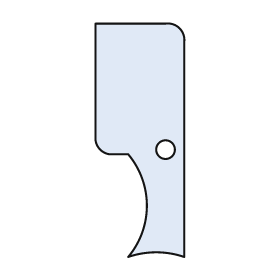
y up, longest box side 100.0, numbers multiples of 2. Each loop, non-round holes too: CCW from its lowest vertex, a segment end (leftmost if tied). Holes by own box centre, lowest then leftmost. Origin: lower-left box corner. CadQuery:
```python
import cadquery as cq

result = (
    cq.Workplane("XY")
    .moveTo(14.0, 0.0)
    .threePointArc((26.0, 2.0), (38.0, 0.0))
    .lineTo(38.0, 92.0)
    .threePointArc((36.0, 98.0), (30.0, 100.0))
    .lineTo(0.0, 100.0)
    .lineTo(0.0, 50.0)
    .threePointArc((2.0, 46.0), (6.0, 44.0))
    .lineTo(14.0, 44.0)
    .threePointArc((22.0, 22.0), (14.0, 0.0))
    .close()
    .moveTo(30.0, 46.0)
    .circle(4.0)
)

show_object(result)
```